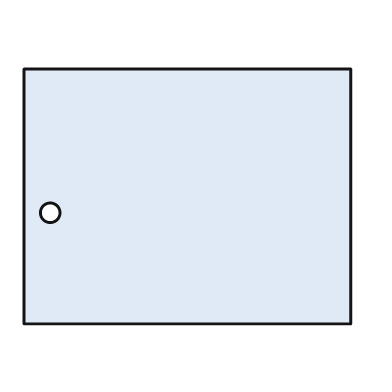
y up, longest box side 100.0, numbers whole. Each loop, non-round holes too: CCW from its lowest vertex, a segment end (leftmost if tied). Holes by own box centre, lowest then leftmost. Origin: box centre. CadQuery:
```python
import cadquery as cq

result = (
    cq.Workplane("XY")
    .moveTo(-50.0, -39.0)
    .lineTo(50.0, -39.0)
    .lineTo(50.0, 39.0)
    .lineTo(-50.0, 39.0)
    .close()
    .moveTo(-42.0, -5.0)
    .circle(3.0)
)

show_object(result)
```